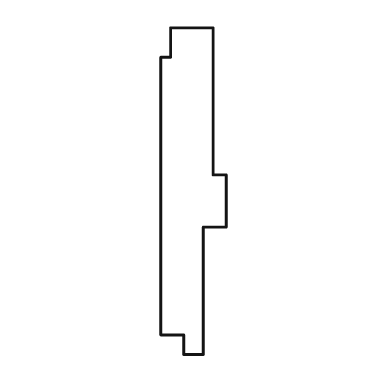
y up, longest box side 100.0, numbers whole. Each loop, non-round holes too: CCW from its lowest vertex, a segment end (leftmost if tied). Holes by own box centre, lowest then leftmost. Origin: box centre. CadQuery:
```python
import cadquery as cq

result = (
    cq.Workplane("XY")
    .moveTo(-3.0, -50.0)
    .lineTo(3.0, -50.0)
    .lineTo(3.0, -11.0)
    .lineTo(10.0, -11.0)
    .lineTo(10.0, 5.0)
    .lineTo(6.0, 5.0)
    .lineTo(6.0, 50.0)
    .lineTo(-7.0, 50.0)
    .lineTo(-7.0, 41.0)
    .lineTo(-10.0, 41.0)
    .lineTo(-10.0, -44.0)
    .lineTo(-3.0, -44.0)
    .close()
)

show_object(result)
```